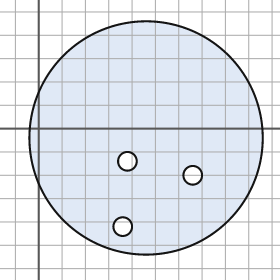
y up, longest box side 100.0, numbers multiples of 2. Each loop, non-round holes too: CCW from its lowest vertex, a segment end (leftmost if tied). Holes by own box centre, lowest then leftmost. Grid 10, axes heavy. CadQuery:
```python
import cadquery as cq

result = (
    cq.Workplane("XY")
    .moveTo(46.0, -4.0)
    .circle(50.0)
    .moveTo(36.0, -42.0)
    .circle(4.0)
    .moveTo(66.0, -20.0)
    .circle(4.0)
    .moveTo(38.0, -14.0)
    .circle(4.0)
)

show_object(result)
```